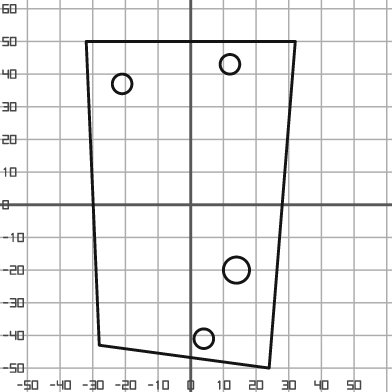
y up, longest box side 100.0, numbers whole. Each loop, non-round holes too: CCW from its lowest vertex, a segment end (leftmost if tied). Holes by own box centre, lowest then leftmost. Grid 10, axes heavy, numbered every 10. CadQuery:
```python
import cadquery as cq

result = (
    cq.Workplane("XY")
    .moveTo(24.0, -50.0)
    .lineTo(32.0, 50.0)
    .lineTo(-32.0, 50.0)
    .lineTo(-28.0, -43.0)
    .close()
    .moveTo(4.0, -41.0)
    .circle(3.0)
    .moveTo(14.0, -20.0)
    .circle(4.0)
    .moveTo(-21.0, 37.0)
    .circle(3.0)
    .moveTo(12.0, 43.0)
    .circle(3.0)
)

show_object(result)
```